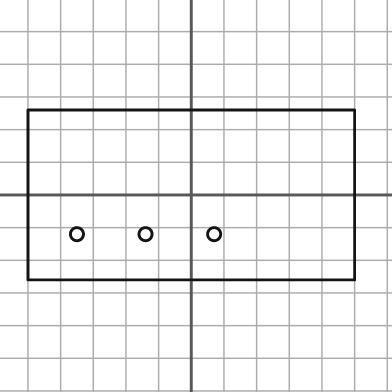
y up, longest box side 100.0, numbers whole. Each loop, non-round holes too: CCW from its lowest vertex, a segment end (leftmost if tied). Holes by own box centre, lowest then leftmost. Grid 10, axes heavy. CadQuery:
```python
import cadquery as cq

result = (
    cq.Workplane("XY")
    .moveTo(-50.0, -26.0)
    .lineTo(50.0, -26.0)
    .lineTo(50.0, 26.0)
    .lineTo(-50.0, 26.0)
    .close()
    .moveTo(-35.0, -12.0)
    .circle(2.0)
    .moveTo(-14.0, -12.0)
    .circle(2.0)
    .moveTo(7.0, -12.0)
    .circle(2.0)
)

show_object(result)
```